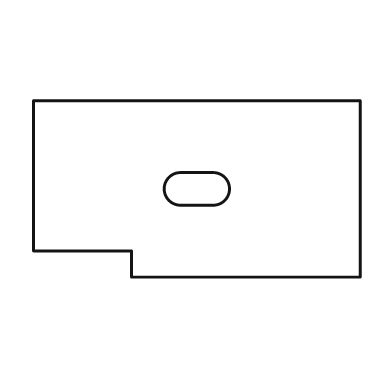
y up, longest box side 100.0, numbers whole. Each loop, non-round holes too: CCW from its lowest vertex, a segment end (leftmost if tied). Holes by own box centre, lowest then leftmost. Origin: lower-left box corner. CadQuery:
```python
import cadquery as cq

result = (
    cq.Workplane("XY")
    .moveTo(30.0, 0.0)
    .lineTo(100.0, 0.0)
    .lineTo(100.0, 54.0)
    .lineTo(0.0, 54.0)
    .lineTo(0.0, 8.0)
    .lineTo(30.0, 8.0)
    .close()
    .moveTo(45.0, 22.0)
    .lineTo(55.0, 22.0)
    .threePointArc((60.0, 27.0), (55.0, 32.0))
    .lineTo(45.0, 32.0)
    .threePointArc((40.0, 27.0), (45.0, 22.0))
    .close()
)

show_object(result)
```